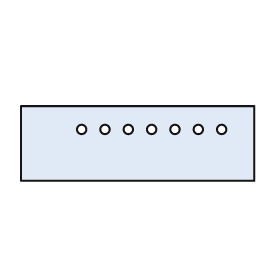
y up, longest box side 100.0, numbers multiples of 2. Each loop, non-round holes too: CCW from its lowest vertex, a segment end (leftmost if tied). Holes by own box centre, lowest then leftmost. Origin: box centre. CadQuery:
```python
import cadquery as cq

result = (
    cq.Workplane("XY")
    .moveTo(-50.0, -16.0)
    .lineTo(50.0, -16.0)
    .lineTo(50.0, 16.0)
    .lineTo(-50.0, 16.0)
    .close()
    .moveTo(-24.0, 6.0)
    .circle(2.0)
    .moveTo(-14.0, 6.0)
    .circle(2.0)
    .moveTo(-4.0, 6.0)
    .circle(2.0)
    .moveTo(6.0, 6.0)
    .circle(2.0)
    .moveTo(16.0, 6.0)
    .circle(2.0)
    .moveTo(26.0, 6.0)
    .circle(2.0)
    .moveTo(36.0, 6.0)
    .circle(2.0)
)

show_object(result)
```